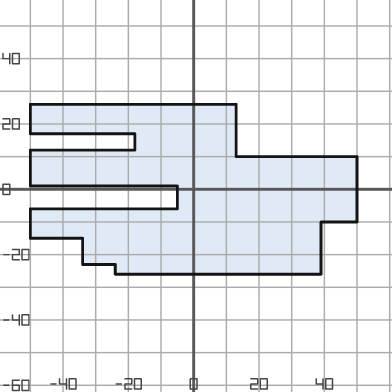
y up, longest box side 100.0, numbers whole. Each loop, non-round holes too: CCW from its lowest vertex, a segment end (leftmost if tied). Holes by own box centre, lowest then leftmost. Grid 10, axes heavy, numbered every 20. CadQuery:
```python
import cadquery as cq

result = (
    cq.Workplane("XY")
    .moveTo(-24.0, -26.0)
    .lineTo(39.0, -26.0)
    .lineTo(39.0, -10.0)
    .lineTo(50.0, -10.0)
    .lineTo(50.0, 10.0)
    .lineTo(13.0, 10.0)
    .lineTo(13.0, 26.0)
    .lineTo(-50.0, 26.0)
    .lineTo(-50.0, 17.0)
    .lineTo(-18.0, 17.0)
    .lineTo(-18.0, 12.0)
    .lineTo(-50.0, 12.0)
    .lineTo(-50.0, 1.0)
    .lineTo(-5.0, 1.0)
    .lineTo(-5.0, -6.0)
    .lineTo(-50.0, -6.0)
    .lineTo(-50.0, -15.0)
    .lineTo(-34.0, -15.0)
    .lineTo(-34.0, -23.0)
    .lineTo(-24.0, -23.0)
    .close()
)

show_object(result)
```